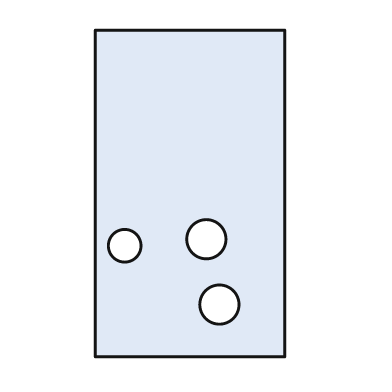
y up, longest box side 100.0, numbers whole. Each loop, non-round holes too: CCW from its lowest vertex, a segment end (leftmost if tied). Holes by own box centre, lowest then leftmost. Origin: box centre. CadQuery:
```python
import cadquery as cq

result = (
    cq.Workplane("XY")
    .moveTo(-29.0, -50.0)
    .lineTo(29.0, -50.0)
    .lineTo(29.0, 50.0)
    .lineTo(-29.0, 50.0)
    .close()
    .moveTo(9.0, -34.0)
    .circle(6.0)
    .moveTo(-20.0, -16.0)
    .circle(5.0)
    .moveTo(5.0, -14.0)
    .circle(6.0)
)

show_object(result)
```